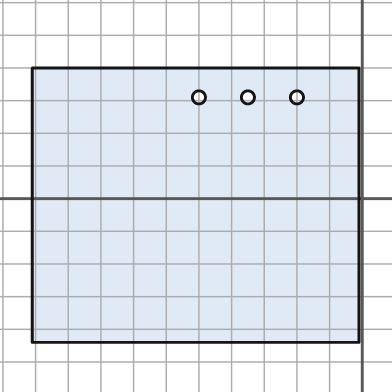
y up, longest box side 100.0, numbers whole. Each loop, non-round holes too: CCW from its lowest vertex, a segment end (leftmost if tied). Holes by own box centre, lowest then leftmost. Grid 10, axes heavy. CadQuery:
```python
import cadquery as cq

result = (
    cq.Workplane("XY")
    .moveTo(-101.0, -44.0)
    .lineTo(-1.0, -44.0)
    .lineTo(-1.0, 40.0)
    .lineTo(-101.0, 40.0)
    .close()
    .moveTo(-50.0, 31.0)
    .circle(2.0)
    .moveTo(-35.0, 31.0)
    .circle(2.0)
    .moveTo(-20.0, 31.0)
    .circle(2.0)
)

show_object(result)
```